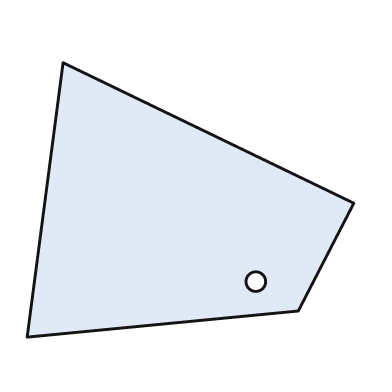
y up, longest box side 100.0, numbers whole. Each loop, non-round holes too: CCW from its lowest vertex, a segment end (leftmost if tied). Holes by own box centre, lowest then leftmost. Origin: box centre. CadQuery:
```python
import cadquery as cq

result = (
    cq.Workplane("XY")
    .moveTo(-50.0, -42.0)
    .lineTo(33.0, -34.0)
    .lineTo(50.0, -1.0)
    .lineTo(-39.0, 42.0)
    .close()
    .moveTo(20.0, -25.0)
    .circle(3.0)
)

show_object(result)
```